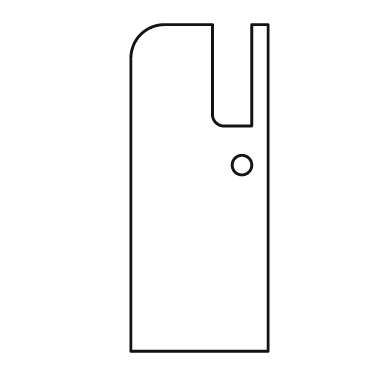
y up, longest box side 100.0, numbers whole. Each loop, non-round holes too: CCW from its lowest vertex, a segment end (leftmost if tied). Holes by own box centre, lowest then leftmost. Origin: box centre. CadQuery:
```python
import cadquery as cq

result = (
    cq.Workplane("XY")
    .moveTo(-21.0, -50.0)
    .lineTo(21.0, -50.0)
    .lineTo(21.0, 50.0)
    .lineTo(16.0, 50.0)
    .lineTo(16.0, 19.0)
    .lineTo(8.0, 19.0)
    .threePointArc((5.0, 20.0), (4.0, 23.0))
    .lineTo(4.0, 50.0)
    .lineTo(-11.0, 50.0)
    .threePointArc((-18.0, 47.0), (-21.0, 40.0))
    .close()
    .moveTo(13.0, 7.0)
    .circle(3.0)
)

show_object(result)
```